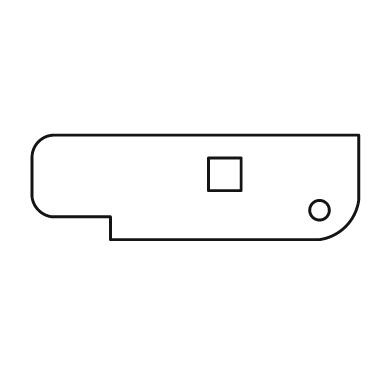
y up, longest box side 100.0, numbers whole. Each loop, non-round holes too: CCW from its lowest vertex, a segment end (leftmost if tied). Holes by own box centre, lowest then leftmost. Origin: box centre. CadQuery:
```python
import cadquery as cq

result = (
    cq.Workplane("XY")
    .moveTo(-26.0, -16.0)
    .lineTo(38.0, -16.0)
    .threePointArc((46.0, -12.0), (50.0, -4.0))
    .lineTo(50.0, 16.0)
    .lineTo(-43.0, 16.0)
    .threePointArc((-48.0, 14.0), (-50.0, 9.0))
    .lineTo(-50.0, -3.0)
    .threePointArc((-48.0, -7.0), (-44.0, -9.0))
    .lineTo(-26.0, -9.0)
    .close()
    .moveTo(38.0, -7.0)
    .circle(3.0)
    .moveTo(4.0, -1.0)
    .lineTo(14.0, -1.0)
    .lineTo(14.0, 9.0)
    .lineTo(4.0, 9.0)
    .close()
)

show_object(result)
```